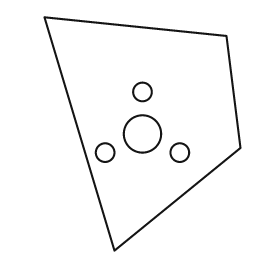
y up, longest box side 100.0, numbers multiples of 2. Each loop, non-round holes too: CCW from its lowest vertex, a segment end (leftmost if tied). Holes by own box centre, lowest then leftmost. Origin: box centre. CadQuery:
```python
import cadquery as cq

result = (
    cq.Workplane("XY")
    .moveTo(-12.0, -50.0)
    .lineTo(42.0, -6.0)
    .lineTo(36.0, 42.0)
    .lineTo(-42.0, 50.0)
    .close()
    .moveTo(-16.0, -8.0)
    .circle(4.0)
    .moveTo(16.0, -8.0)
    .circle(4.0)
    .moveTo(0.0, 0.0)
    .circle(8.0)
    .moveTo(0.0, 18.0)
    .circle(4.0)
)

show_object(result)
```